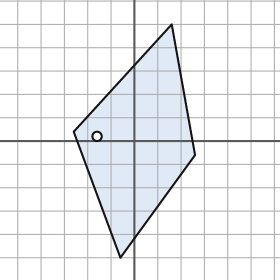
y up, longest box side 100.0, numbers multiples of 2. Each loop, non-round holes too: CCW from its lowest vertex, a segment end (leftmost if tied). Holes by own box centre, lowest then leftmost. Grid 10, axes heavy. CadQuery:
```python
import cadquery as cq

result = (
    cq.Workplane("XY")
    .moveTo(-6.0, -50.0)
    .lineTo(26.0, -6.0)
    .lineTo(16.0, 50.0)
    .lineTo(-26.0, 4.0)
    .close()
    .moveTo(-16.0, 2.0)
    .circle(2.0)
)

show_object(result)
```